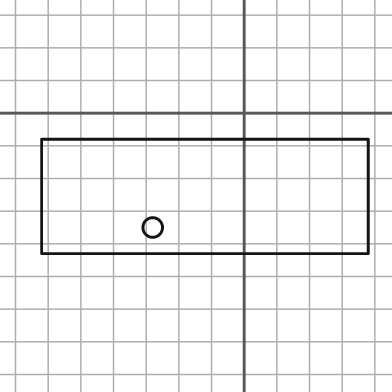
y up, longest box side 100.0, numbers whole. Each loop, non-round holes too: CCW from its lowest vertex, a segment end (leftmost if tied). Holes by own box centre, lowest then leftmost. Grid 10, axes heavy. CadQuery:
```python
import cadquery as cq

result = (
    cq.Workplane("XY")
    .moveTo(-62.0, -43.0)
    .lineTo(38.0, -43.0)
    .lineTo(38.0, -8.0)
    .lineTo(-62.0, -8.0)
    .close()
    .moveTo(-28.0, -35.0)
    .circle(3.0)
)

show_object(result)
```